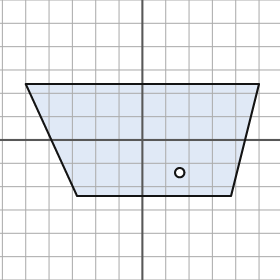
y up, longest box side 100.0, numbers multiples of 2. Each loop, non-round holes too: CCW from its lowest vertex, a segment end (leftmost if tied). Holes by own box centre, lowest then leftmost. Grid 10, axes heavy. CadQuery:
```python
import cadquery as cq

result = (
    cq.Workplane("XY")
    .moveTo(-28.0, -24.0)
    .lineTo(38.0, -24.0)
    .lineTo(50.0, 24.0)
    .lineTo(-50.0, 24.0)
    .close()
    .moveTo(16.0, -14.0)
    .circle(2.0)
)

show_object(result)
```